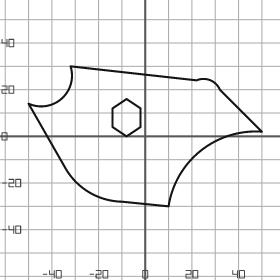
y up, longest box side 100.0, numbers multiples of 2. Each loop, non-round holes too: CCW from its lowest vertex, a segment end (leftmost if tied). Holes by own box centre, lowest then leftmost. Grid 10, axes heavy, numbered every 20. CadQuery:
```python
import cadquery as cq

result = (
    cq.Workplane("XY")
    .moveTo(10.0, -30.0)
    .threePointArc((24.0, -6.0), (50.0, 2.0))
    .lineTo(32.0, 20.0)
    .threePointArc((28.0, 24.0), (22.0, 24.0))
    .lineTo(-32.0, 30.0)
    .threePointArc((-36.0, 16.0), (-50.0, 14.0))
    .lineTo(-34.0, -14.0)
    .threePointArc((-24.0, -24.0), (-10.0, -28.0))
    .close()
    .moveTo(-8.0, 0.0)
    .lineTo(-2.0, 4.0)
    .lineTo(-2.0, 12.0)
    .lineTo(-8.0, 16.0)
    .lineTo(-14.0, 12.0)
    .lineTo(-14.0, 4.0)
    .close()
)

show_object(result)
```